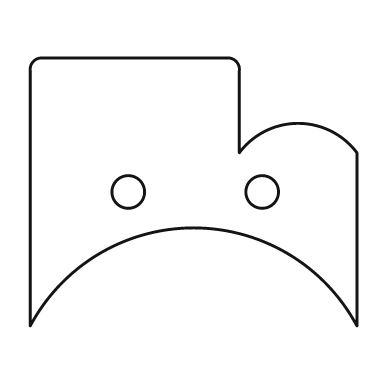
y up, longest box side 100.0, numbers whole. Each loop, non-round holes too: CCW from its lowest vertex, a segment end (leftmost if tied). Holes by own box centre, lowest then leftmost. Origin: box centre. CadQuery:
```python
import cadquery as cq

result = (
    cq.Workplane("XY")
    .moveTo(-50.0, -41.0)
    .threePointArc((0.0, -11.0), (50.0, -41.0))
    .lineTo(50.0, 12.0)
    .threePointArc((32.0, 21.0), (14.0, 12.0))
    .lineTo(14.0, 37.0)
    .threePointArc((13.0, 40.0), (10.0, 41.0))
    .lineTo(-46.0, 41.0)
    .threePointArc((-49.0, 40.0), (-50.0, 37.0))
    .close()
    .moveTo(-20.0, 0.0)
    .circle(5.0)
    .moveTo(21.0, 0.0)
    .circle(5.0)
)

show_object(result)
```